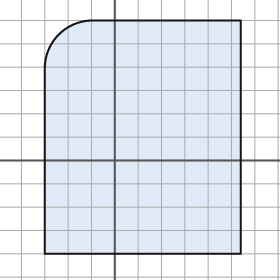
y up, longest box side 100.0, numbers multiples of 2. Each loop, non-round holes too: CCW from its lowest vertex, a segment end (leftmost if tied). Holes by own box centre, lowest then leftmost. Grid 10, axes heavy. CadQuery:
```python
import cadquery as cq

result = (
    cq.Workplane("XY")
    .moveTo(-30.0, -40.0)
    .lineTo(54.0, -40.0)
    .lineTo(54.0, 60.0)
    .lineTo(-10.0, 60.0)
    .threePointArc((-24.0, 54.0), (-30.0, 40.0))
    .close()
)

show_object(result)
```